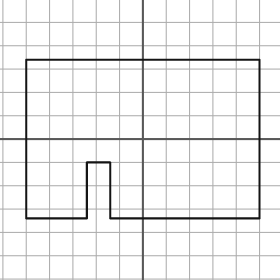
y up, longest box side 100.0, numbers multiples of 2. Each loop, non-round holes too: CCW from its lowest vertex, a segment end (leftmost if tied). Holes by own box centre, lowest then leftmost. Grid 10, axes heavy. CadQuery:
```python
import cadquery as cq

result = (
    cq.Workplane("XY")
    .moveTo(-50.0, -34.0)
    .lineTo(-24.0, -34.0)
    .lineTo(-24.0, -10.0)
    .lineTo(-14.0, -10.0)
    .lineTo(-14.0, -34.0)
    .lineTo(50.0, -34.0)
    .lineTo(50.0, 34.0)
    .lineTo(-50.0, 34.0)
    .close()
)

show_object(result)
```